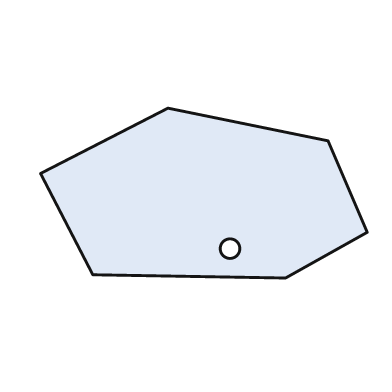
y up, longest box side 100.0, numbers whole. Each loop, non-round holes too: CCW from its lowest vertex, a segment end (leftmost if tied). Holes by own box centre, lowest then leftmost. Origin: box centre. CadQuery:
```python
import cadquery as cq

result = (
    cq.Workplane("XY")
    .moveTo(25.0, -26.0)
    .lineTo(50.0, -12.0)
    .lineTo(38.0, 16.0)
    .lineTo(-11.0, 26.0)
    .lineTo(-50.0, 6.0)
    .lineTo(-34.0, -25.0)
    .close()
    .moveTo(8.0, -17.0)
    .circle(3.0)
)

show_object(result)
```